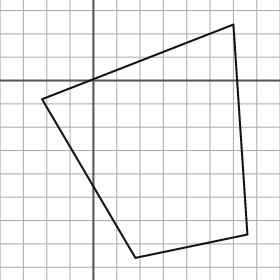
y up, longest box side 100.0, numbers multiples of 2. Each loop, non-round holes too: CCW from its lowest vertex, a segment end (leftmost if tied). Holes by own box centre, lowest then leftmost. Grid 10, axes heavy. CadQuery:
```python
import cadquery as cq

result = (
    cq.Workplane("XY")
    .moveTo(18.0, -76.0)
    .lineTo(66.0, -66.0)
    .lineTo(60.0, 24.0)
    .lineTo(-22.0, -8.0)
    .close()
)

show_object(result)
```